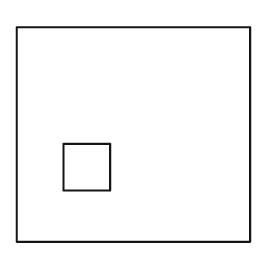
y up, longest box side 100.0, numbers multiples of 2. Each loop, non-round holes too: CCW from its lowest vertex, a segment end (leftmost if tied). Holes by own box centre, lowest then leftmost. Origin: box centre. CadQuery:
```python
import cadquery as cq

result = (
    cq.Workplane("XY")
    .moveTo(-50.0, -46.0)
    .lineTo(50.0, -46.0)
    .lineTo(50.0, 46.0)
    .lineTo(-50.0, 46.0)
    .close()
    .moveTo(-30.0, -24.0)
    .lineTo(-10.0, -24.0)
    .lineTo(-10.0, -4.0)
    .lineTo(-30.0, -4.0)
    .close()
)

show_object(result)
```